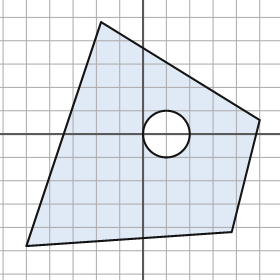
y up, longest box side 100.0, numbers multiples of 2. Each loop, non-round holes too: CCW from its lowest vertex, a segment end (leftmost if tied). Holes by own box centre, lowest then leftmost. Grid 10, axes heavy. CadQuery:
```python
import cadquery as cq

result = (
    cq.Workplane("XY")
    .moveTo(-50.0, -48.0)
    .lineTo(38.0, -42.0)
    .lineTo(50.0, 6.0)
    .lineTo(-18.0, 48.0)
    .close()
    .moveTo(10.0, 0.0)
    .circle(10.0)
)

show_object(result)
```